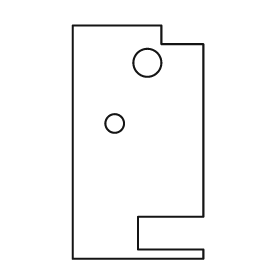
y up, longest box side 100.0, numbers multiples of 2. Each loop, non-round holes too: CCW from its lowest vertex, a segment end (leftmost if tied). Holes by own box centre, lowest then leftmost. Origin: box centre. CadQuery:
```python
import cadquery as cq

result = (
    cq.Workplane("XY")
    .moveTo(-28.0, -50.0)
    .lineTo(28.0, -50.0)
    .lineTo(28.0, -46.0)
    .lineTo(0.0, -46.0)
    .lineTo(0.0, -32.0)
    .lineTo(28.0, -32.0)
    .lineTo(28.0, 42.0)
    .lineTo(10.0, 42.0)
    .lineTo(10.0, 50.0)
    .lineTo(-28.0, 50.0)
    .close()
    .moveTo(-10.0, 8.0)
    .circle(4.0)
    .moveTo(4.0, 34.0)
    .circle(6.0)
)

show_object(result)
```